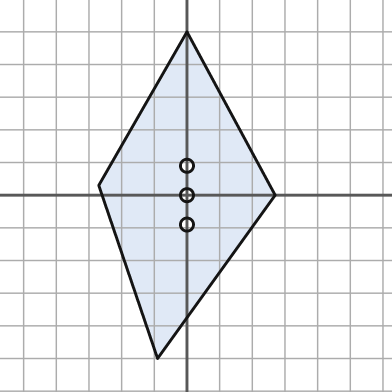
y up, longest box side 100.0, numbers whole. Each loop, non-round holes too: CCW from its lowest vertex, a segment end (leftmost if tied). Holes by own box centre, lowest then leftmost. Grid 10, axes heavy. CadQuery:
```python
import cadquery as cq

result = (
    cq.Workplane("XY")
    .moveTo(-9.0, -50.0)
    .lineTo(27.0, 0.0)
    .lineTo(0.0, 50.0)
    .lineTo(-27.0, 3.0)
    .close()
    .moveTo(0.0, -9.0)
    .circle(2.0)
    .moveTo(0.0, 0.0)
    .circle(2.0)
    .moveTo(0.0, 9.0)
    .circle(2.0)
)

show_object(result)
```